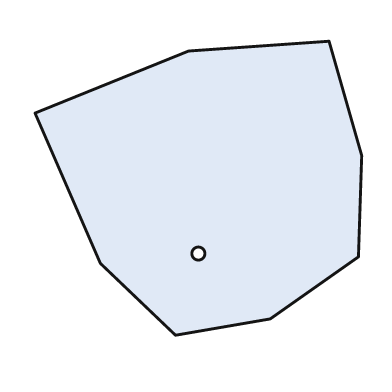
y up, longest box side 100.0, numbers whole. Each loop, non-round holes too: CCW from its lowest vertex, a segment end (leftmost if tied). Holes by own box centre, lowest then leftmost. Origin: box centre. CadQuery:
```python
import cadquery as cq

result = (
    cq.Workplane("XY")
    .moveTo(-7.0, -45.0)
    .lineTo(22.0, -40.0)
    .lineTo(49.0, -21.0)
    .lineTo(50.0, 10.0)
    .lineTo(40.0, 45.0)
    .lineTo(-3.0, 42.0)
    .lineTo(-50.0, 23.0)
    .lineTo(-30.0, -23.0)
    .close()
    .moveTo(0.0, -20.0)
    .circle(2.0)
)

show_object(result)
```